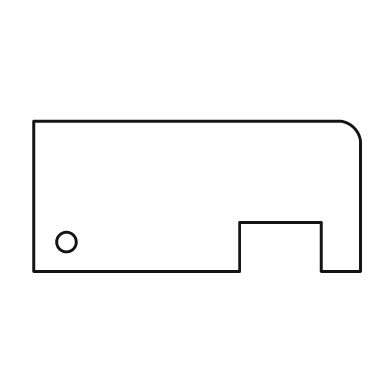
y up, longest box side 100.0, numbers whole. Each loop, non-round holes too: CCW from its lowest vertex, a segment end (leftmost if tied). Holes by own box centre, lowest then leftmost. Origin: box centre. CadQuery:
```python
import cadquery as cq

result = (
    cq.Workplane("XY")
    .moveTo(-50.0, -23.0)
    .lineTo(13.0, -23.0)
    .lineTo(13.0, -8.0)
    .lineTo(38.0, -8.0)
    .lineTo(38.0, -23.0)
    .lineTo(50.0, -23.0)
    .lineTo(50.0, 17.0)
    .threePointArc((48.0, 21.0), (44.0, 23.0))
    .lineTo(-50.0, 23.0)
    .close()
    .moveTo(-40.0, -14.0)
    .circle(3.0)
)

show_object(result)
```